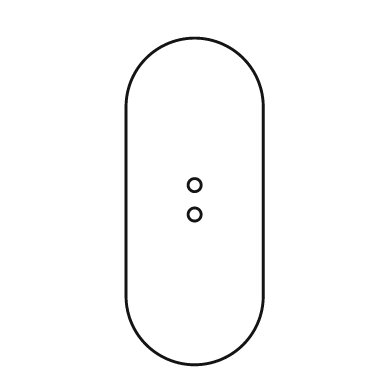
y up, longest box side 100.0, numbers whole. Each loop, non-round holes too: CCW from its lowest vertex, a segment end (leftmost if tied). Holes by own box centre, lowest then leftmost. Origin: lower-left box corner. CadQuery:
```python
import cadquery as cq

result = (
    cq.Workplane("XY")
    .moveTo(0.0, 21.0)
    .threePointArc((21.0, 0.0), (42.0, 21.0))
    .lineTo(42.0, 79.0)
    .threePointArc((21.0, 100.0), (0.0, 79.0))
    .close()
    .moveTo(21.0, 46.0)
    .circle(2.0)
    .moveTo(21.0, 55.0)
    .circle(2.0)
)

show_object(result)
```